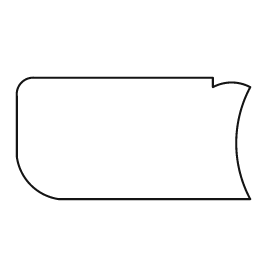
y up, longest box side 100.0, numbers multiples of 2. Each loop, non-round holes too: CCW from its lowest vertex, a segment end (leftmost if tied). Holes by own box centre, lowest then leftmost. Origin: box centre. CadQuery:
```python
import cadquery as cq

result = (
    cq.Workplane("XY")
    .moveTo(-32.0, -26.0)
    .lineTo(50.0, -26.0)
    .threePointArc((44.0, -2.0), (50.0, 22.0))
    .threePointArc((42.0, 24.0), (34.0, 22.0))
    .lineTo(34.0, 26.0)
    .lineTo(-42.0, 26.0)
    .threePointArc((-48.0, 24.0), (-50.0, 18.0))
    .lineTo(-50.0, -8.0)
    .threePointArc((-44.0, -20.0), (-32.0, -26.0))
    .close()
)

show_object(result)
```